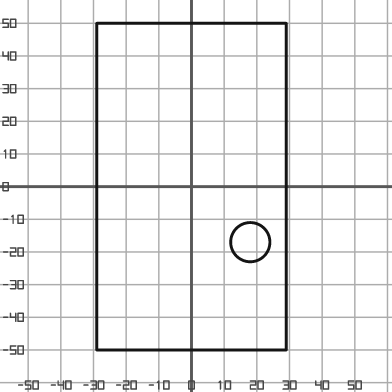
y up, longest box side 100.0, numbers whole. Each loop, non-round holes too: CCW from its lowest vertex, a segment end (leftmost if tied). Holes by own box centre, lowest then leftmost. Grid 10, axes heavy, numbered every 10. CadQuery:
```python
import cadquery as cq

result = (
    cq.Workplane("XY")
    .moveTo(-29.0, -50.0)
    .lineTo(29.0, -50.0)
    .lineTo(29.0, 50.0)
    .lineTo(-29.0, 50.0)
    .close()
    .moveTo(18.0, -17.0)
    .circle(6.0)
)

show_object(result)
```